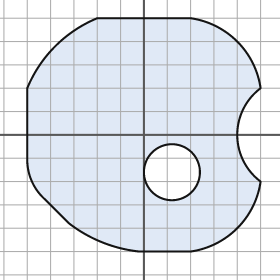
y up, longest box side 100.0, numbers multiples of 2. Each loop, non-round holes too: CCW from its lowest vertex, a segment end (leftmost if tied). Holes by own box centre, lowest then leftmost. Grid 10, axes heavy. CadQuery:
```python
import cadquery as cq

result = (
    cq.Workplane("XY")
    .moveTo(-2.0, -50.0)
    .lineTo(20.0, -50.0)
    .threePointArc((40.0, -40.0), (50.0, -20.0))
    .threePointArc((40.0, 0.0), (50.0, 20.0))
    .threePointArc((40.0, 40.0), (20.0, 50.0))
    .lineTo(-20.0, 50.0)
    .threePointArc((-38.0, 38.0), (-50.0, 20.0))
    .lineTo(-50.0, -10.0)
    .threePointArc((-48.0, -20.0), (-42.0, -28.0))
    .lineTo(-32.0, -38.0)
    .threePointArc((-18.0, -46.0), (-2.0, -50.0))
    .close()
    .moveTo(12.0, -16.0)
    .circle(12.0)
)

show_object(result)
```